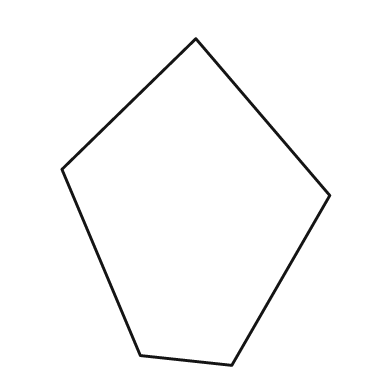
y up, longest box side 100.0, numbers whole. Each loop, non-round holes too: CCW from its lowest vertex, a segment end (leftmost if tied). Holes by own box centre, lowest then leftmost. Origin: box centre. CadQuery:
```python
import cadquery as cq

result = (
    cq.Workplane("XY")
    .moveTo(11.0, -50.0)
    .lineTo(41.0, 2.0)
    .lineTo(0.0, 50.0)
    .lineTo(-41.0, 10.0)
    .lineTo(-17.0, -47.0)
    .close()
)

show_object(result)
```